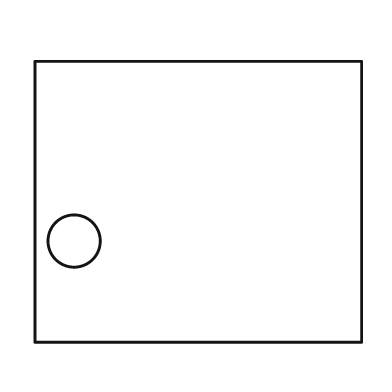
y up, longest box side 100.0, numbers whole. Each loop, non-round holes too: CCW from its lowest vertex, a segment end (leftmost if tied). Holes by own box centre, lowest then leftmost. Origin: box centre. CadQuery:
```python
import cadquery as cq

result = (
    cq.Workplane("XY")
    .moveTo(-50.0, -43.0)
    .lineTo(50.0, -43.0)
    .lineTo(50.0, 43.0)
    .lineTo(-50.0, 43.0)
    .close()
    .moveTo(-38.0, -12.0)
    .circle(8.0)
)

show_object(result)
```